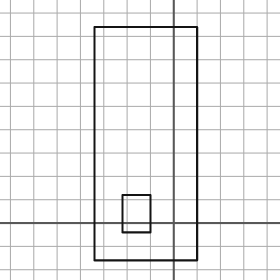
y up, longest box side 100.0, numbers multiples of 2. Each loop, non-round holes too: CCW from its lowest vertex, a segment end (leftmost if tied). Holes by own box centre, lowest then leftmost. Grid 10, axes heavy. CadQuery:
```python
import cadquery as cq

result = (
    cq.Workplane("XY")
    .moveTo(-34.0, -16.0)
    .lineTo(10.0, -16.0)
    .lineTo(10.0, 84.0)
    .lineTo(-34.0, 84.0)
    .close()
    .moveTo(-22.0, -4.0)
    .lineTo(-10.0, -4.0)
    .lineTo(-10.0, 12.0)
    .lineTo(-22.0, 12.0)
    .close()
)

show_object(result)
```